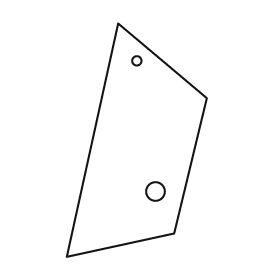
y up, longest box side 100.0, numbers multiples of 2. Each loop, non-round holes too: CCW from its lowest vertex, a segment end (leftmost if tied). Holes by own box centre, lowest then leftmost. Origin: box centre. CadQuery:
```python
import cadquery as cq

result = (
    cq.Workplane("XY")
    .moveTo(-30.0, -50.0)
    .lineTo(16.0, -40.0)
    .lineTo(30.0, 18.0)
    .lineTo(-8.0, 50.0)
    .close()
    .moveTo(8.0, -22.0)
    .circle(4.0)
    .moveTo(0.0, 34.0)
    .circle(2.0)
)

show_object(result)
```